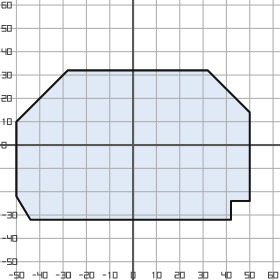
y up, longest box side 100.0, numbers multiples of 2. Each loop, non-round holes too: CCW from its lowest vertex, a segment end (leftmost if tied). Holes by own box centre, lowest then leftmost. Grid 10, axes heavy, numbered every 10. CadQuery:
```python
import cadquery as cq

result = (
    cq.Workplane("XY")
    .moveTo(-44.0, -32.0)
    .lineTo(42.0, -32.0)
    .lineTo(42.0, -24.0)
    .lineTo(50.0, -24.0)
    .lineTo(50.0, 14.0)
    .lineTo(32.0, 32.0)
    .lineTo(-28.0, 32.0)
    .lineTo(-50.0, 10.0)
    .lineTo(-50.0, -22.0)
    .close()
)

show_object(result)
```